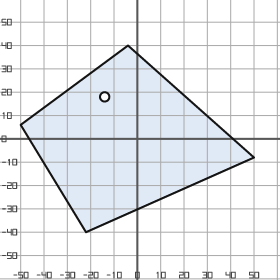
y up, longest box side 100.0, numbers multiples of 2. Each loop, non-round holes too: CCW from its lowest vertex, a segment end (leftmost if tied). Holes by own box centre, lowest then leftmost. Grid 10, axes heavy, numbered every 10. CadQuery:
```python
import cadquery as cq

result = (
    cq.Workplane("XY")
    .moveTo(-22.0, -40.0)
    .lineTo(50.0, -8.0)
    .lineTo(-4.0, 40.0)
    .lineTo(-50.0, 6.0)
    .close()
    .moveTo(-14.0, 18.0)
    .circle(2.0)
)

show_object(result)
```